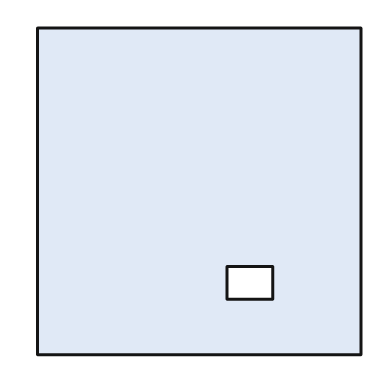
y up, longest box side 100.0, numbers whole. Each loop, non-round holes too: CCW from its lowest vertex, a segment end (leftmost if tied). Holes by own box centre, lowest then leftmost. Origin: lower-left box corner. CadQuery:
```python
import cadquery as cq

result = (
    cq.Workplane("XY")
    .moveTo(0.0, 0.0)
    .lineTo(99.0, 0.0)
    .lineTo(99.0, 100.0)
    .lineTo(0.0, 100.0)
    .close()
    .moveTo(58.0, 17.0)
    .lineTo(72.0, 17.0)
    .lineTo(72.0, 27.0)
    .lineTo(58.0, 27.0)
    .close()
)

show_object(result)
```